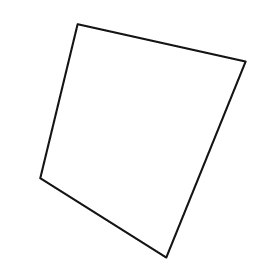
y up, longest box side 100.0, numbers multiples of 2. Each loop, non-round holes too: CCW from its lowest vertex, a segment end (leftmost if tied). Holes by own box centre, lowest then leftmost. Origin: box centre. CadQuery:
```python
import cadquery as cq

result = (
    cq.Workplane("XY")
    .moveTo(10.0, -50.0)
    .lineTo(44.0, 34.0)
    .lineTo(-28.0, 50.0)
    .lineTo(-44.0, -16.0)
    .close()
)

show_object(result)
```